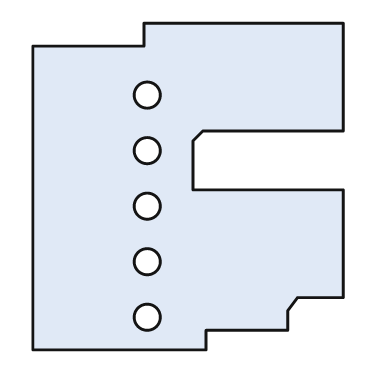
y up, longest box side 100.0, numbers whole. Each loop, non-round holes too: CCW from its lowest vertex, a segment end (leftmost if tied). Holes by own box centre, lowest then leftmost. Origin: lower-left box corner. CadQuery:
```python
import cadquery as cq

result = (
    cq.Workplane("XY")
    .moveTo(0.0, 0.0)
    .lineTo(53.0, 0.0)
    .lineTo(53.0, 6.0)
    .lineTo(78.0, 6.0)
    .lineTo(78.0, 12.0)
    .lineTo(81.0, 16.0)
    .lineTo(95.0, 16.0)
    .lineTo(95.0, 49.0)
    .lineTo(49.0, 49.0)
    .lineTo(49.0, 64.0)
    .lineTo(52.0, 67.0)
    .lineTo(95.0, 67.0)
    .lineTo(95.0, 100.0)
    .lineTo(34.0, 100.0)
    .lineTo(34.0, 93.0)
    .lineTo(0.0, 93.0)
    .close()
    .moveTo(35.0, 10.0)
    .circle(4.0)
    .moveTo(35.0, 27.0)
    .circle(4.0)
    .moveTo(35.0, 44.0)
    .circle(4.0)
    .moveTo(35.0, 61.0)
    .circle(4.0)
    .moveTo(35.0, 78.0)
    .circle(4.0)
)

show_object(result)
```